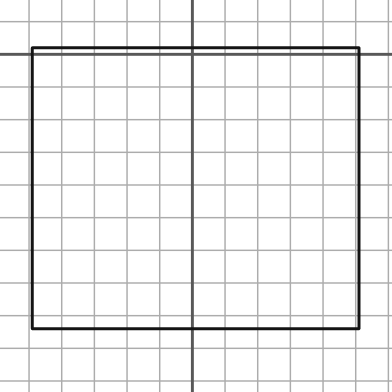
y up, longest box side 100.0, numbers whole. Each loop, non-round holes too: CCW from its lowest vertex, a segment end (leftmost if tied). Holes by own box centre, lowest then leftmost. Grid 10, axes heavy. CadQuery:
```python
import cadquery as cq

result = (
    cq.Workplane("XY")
    .moveTo(-49.0, -84.0)
    .lineTo(51.0, -84.0)
    .lineTo(51.0, 2.0)
    .lineTo(-49.0, 2.0)
    .close()
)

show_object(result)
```